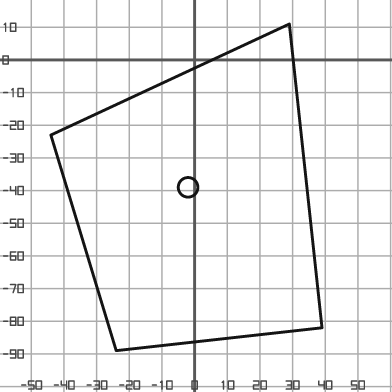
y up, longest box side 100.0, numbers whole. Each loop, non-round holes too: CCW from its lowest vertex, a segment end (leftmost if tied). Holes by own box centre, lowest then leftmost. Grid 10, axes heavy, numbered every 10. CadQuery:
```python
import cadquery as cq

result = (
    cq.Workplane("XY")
    .moveTo(-24.0, -89.0)
    .lineTo(39.0, -82.0)
    .lineTo(29.0, 11.0)
    .lineTo(-44.0, -23.0)
    .close()
    .moveTo(-2.0, -39.0)
    .circle(3.0)
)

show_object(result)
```